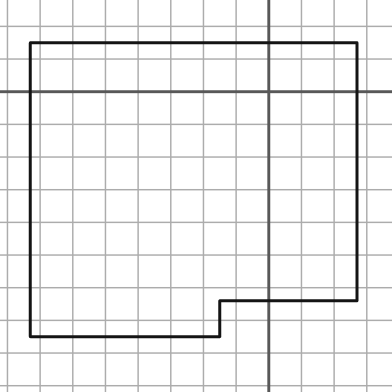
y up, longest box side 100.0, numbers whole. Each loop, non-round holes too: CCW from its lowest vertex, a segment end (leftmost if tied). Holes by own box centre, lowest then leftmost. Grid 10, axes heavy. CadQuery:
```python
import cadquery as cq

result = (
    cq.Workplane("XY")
    .moveTo(-73.0, -75.0)
    .lineTo(-15.0, -75.0)
    .lineTo(-15.0, -64.0)
    .lineTo(27.0, -64.0)
    .lineTo(27.0, 15.0)
    .lineTo(-73.0, 15.0)
    .close()
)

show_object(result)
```